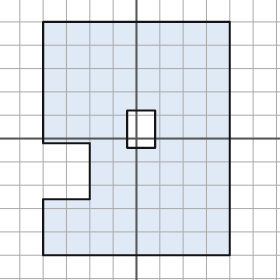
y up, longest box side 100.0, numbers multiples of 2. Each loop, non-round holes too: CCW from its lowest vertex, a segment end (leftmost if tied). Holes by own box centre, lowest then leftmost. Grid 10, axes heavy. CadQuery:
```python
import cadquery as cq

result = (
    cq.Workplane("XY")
    .moveTo(-40.0, -50.0)
    .lineTo(40.0, -50.0)
    .lineTo(40.0, 50.0)
    .lineTo(-40.0, 50.0)
    .lineTo(-40.0, -2.0)
    .lineTo(-20.0, -2.0)
    .lineTo(-20.0, -26.0)
    .lineTo(-40.0, -26.0)
    .close()
    .moveTo(-4.0, -4.0)
    .lineTo(8.0, -4.0)
    .lineTo(8.0, 12.0)
    .lineTo(-4.0, 12.0)
    .close()
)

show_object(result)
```